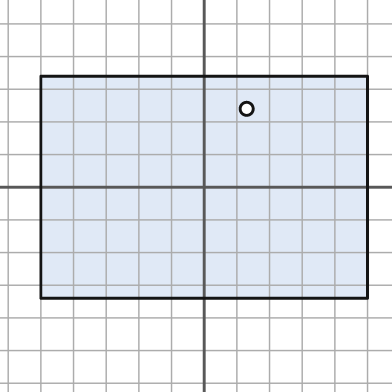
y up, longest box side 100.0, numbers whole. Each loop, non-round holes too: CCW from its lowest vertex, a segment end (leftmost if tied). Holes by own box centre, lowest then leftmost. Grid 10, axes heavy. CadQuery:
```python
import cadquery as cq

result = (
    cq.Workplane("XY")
    .moveTo(-50.0, -34.0)
    .lineTo(50.0, -34.0)
    .lineTo(50.0, 34.0)
    .lineTo(-50.0, 34.0)
    .close()
    .moveTo(13.0, 24.0)
    .circle(2.0)
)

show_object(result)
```